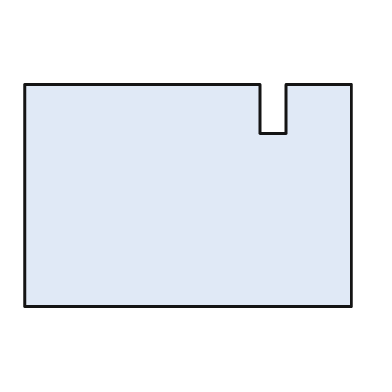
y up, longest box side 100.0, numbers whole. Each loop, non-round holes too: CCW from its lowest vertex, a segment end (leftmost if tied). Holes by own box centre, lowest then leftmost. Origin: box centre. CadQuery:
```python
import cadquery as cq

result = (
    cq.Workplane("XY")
    .moveTo(-50.0, -34.0)
    .lineTo(50.0, -34.0)
    .lineTo(50.0, 34.0)
    .lineTo(30.0, 34.0)
    .lineTo(30.0, 19.0)
    .lineTo(22.0, 19.0)
    .lineTo(22.0, 34.0)
    .lineTo(-50.0, 34.0)
    .close()
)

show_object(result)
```